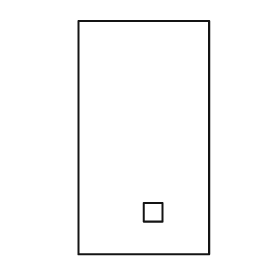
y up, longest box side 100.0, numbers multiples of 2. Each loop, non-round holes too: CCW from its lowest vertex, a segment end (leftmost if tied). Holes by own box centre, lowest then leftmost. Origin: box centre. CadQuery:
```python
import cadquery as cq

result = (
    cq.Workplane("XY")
    .moveTo(-28.0, -50.0)
    .lineTo(28.0, -50.0)
    .lineTo(28.0, 50.0)
    .lineTo(-28.0, 50.0)
    .close()
    .moveTo(0.0, -36.0)
    .lineTo(8.0, -36.0)
    .lineTo(8.0, -28.0)
    .lineTo(0.0, -28.0)
    .close()
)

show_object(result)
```